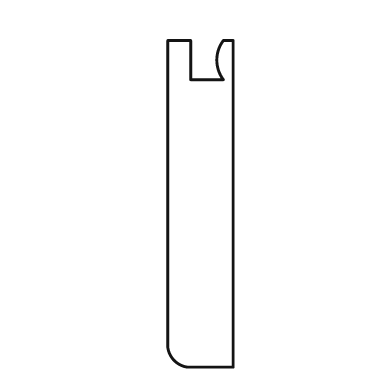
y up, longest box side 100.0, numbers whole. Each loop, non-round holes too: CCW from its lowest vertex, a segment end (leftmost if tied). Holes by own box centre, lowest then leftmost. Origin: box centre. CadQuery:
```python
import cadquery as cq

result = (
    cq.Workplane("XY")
    .moveTo(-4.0, -50.0)
    .lineTo(10.0, -50.0)
    .lineTo(10.0, 50.0)
    .lineTo(7.0, 50.0)
    .threePointArc((5.0, 44.0), (7.0, 38.0))
    .lineTo(-3.0, 38.0)
    .lineTo(-3.0, 50.0)
    .lineTo(-10.0, 50.0)
    .lineTo(-10.0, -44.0)
    .threePointArc((-8.0, -48.0), (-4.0, -50.0))
    .close()
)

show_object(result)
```